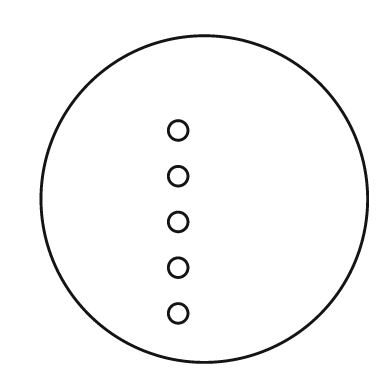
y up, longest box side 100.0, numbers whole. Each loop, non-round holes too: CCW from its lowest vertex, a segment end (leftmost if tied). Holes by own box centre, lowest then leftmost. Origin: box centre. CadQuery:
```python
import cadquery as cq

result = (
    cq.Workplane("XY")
    .moveTo(0.0, 0.0)
    .circle(50.0)
    .moveTo(-8.0, -35.0)
    .circle(3.0)
    .moveTo(-8.0, -21.0)
    .circle(3.0)
    .moveTo(-8.0, -7.0)
    .circle(3.0)
    .moveTo(-8.0, 7.0)
    .circle(3.0)
    .moveTo(-8.0, 21.0)
    .circle(3.0)
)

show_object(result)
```